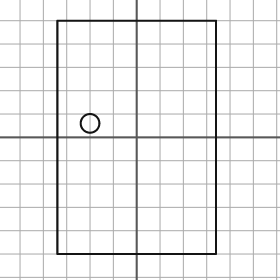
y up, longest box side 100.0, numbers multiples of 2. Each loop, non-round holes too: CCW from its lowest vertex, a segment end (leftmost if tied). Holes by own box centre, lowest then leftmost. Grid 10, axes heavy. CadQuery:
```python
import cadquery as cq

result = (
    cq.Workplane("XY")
    .moveTo(-34.0, -50.0)
    .lineTo(34.0, -50.0)
    .lineTo(34.0, 50.0)
    .lineTo(-34.0, 50.0)
    .close()
    .moveTo(-20.0, 6.0)
    .circle(4.0)
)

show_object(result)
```